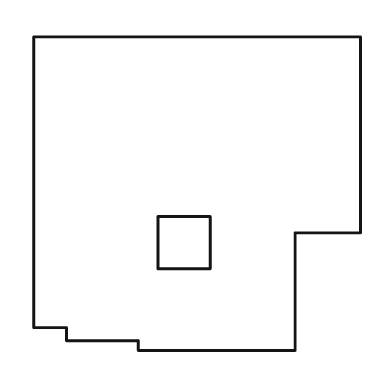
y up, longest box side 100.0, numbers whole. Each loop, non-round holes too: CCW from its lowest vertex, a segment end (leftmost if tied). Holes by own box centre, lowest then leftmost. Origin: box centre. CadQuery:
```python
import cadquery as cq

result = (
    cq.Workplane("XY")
    .moveTo(-18.0, -48.0)
    .lineTo(30.0, -48.0)
    .lineTo(30.0, -12.0)
    .lineTo(50.0, -12.0)
    .lineTo(50.0, 48.0)
    .lineTo(-50.0, 48.0)
    .lineTo(-50.0, -41.0)
    .lineTo(-40.0, -41.0)
    .lineTo(-40.0, -45.0)
    .lineTo(-18.0, -45.0)
    .close()
    .moveTo(-12.0, -23.0)
    .lineTo(4.0, -23.0)
    .lineTo(4.0, -7.0)
    .lineTo(-12.0, -7.0)
    .close()
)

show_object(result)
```